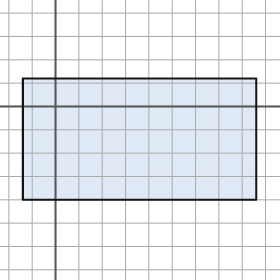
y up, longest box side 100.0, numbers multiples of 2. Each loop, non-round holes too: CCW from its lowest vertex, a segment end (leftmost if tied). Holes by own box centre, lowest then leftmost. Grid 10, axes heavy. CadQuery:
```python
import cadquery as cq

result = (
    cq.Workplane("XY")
    .moveTo(-14.0, -40.0)
    .lineTo(86.0, -40.0)
    .lineTo(86.0, 12.0)
    .lineTo(-14.0, 12.0)
    .close()
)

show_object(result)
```